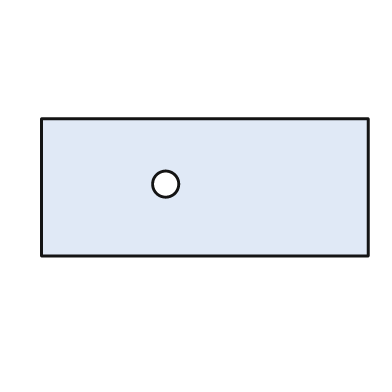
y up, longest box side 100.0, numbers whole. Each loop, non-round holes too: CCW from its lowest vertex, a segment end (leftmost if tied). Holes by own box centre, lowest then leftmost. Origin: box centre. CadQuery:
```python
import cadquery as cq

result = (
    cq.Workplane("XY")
    .moveTo(-50.0, -21.0)
    .lineTo(50.0, -21.0)
    .lineTo(50.0, 21.0)
    .lineTo(-50.0, 21.0)
    .close()
    .moveTo(-12.0, 1.0)
    .circle(4.0)
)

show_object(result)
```